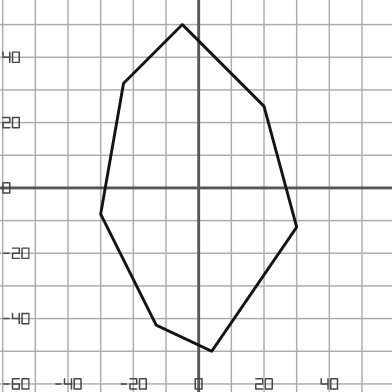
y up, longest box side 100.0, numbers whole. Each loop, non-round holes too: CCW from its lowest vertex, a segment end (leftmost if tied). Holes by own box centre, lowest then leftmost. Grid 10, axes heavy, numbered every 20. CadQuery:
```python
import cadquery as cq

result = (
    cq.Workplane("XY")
    .moveTo(4.0, -50.0)
    .lineTo(30.0, -12.0)
    .lineTo(20.0, 25.0)
    .lineTo(-5.0, 50.0)
    .lineTo(-23.0, 32.0)
    .lineTo(-30.0, -8.0)
    .lineTo(-13.0, -42.0)
    .close()
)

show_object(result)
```